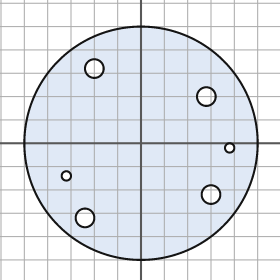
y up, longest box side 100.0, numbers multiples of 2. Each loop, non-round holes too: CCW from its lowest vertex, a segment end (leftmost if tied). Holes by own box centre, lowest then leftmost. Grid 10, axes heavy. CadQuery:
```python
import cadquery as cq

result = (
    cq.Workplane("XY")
    .moveTo(0.0, 0.0)
    .circle(50.0)
    .moveTo(-24.0, -32.0)
    .circle(4.0)
    .moveTo(30.0, -22.0)
    .circle(4.0)
    .moveTo(-32.0, -14.0)
    .circle(2.0)
    .moveTo(38.0, -2.0)
    .circle(2.0)
    .moveTo(28.0, 20.0)
    .circle(4.0)
    .moveTo(-20.0, 32.0)
    .circle(4.0)
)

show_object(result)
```